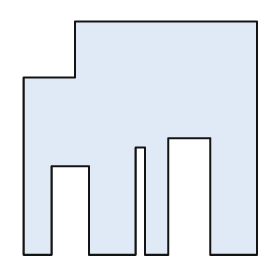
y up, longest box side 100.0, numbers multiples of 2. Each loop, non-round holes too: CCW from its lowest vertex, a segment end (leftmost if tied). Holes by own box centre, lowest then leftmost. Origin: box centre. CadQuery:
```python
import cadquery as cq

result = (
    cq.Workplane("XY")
    .moveTo(-50.0, -50.0)
    .lineTo(-38.0, -50.0)
    .lineTo(-38.0, -12.0)
    .lineTo(-22.0, -12.0)
    .lineTo(-22.0, -50.0)
    .lineTo(-2.0, -50.0)
    .lineTo(-2.0, -4.0)
    .lineTo(2.0, -4.0)
    .lineTo(2.0, -50.0)
    .lineTo(12.0, -50.0)
    .lineTo(12.0, 0.0)
    .lineTo(30.0, 0.0)
    .lineTo(30.0, -50.0)
    .lineTo(50.0, -50.0)
    .lineTo(50.0, 50.0)
    .lineTo(-28.0, 50.0)
    .lineTo(-28.0, 26.0)
    .lineTo(-50.0, 26.0)
    .close()
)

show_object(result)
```